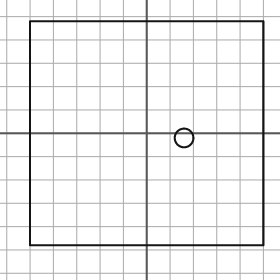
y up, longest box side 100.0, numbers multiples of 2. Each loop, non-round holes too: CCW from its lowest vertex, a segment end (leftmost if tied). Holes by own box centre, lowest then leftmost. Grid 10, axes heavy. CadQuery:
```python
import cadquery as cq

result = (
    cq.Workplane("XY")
    .moveTo(-50.0, -48.0)
    .lineTo(50.0, -48.0)
    .lineTo(50.0, 48.0)
    .lineTo(-50.0, 48.0)
    .close()
    .moveTo(16.0, -2.0)
    .circle(4.0)
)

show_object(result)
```